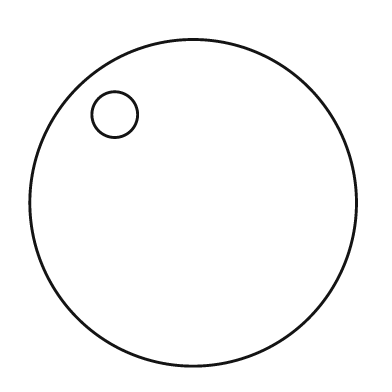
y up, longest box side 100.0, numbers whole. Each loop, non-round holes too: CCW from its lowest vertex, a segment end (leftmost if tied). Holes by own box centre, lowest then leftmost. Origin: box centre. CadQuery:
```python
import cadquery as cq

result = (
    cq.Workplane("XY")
    .moveTo(0.0, 0.0)
    .circle(50.0)
    .moveTo(-24.0, 27.0)
    .circle(7.0)
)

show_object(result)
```